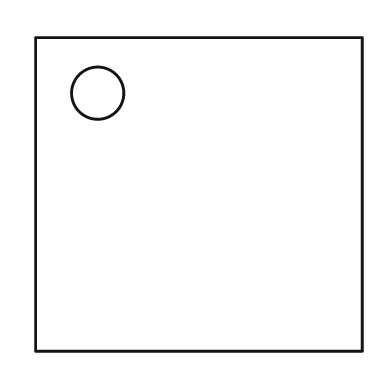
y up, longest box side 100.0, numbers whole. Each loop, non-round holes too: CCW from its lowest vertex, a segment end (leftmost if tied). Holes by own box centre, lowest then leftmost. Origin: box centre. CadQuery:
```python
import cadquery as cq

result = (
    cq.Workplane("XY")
    .moveTo(-50.0, -48.0)
    .lineTo(50.0, -48.0)
    .lineTo(50.0, 48.0)
    .lineTo(-50.0, 48.0)
    .close()
    .moveTo(-31.0, 31.0)
    .circle(8.0)
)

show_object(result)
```